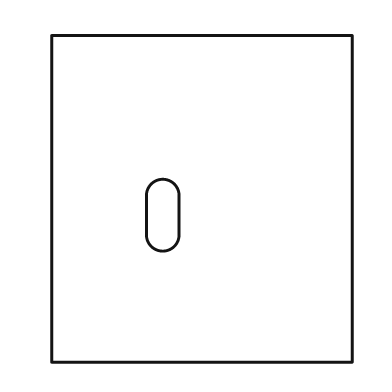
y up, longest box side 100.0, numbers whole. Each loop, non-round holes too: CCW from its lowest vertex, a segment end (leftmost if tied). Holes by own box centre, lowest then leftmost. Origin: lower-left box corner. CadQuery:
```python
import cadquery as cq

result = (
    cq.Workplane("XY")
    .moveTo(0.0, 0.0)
    .lineTo(92.0, 0.0)
    .lineTo(92.0, 100.0)
    .lineTo(0.0, 100.0)
    .close()
    .moveTo(29.0, 39.0)
    .threePointArc((34.0, 34.0), (39.0, 39.0))
    .lineTo(39.0, 51.0)
    .threePointArc((34.0, 56.0), (29.0, 51.0))
    .close()
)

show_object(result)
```